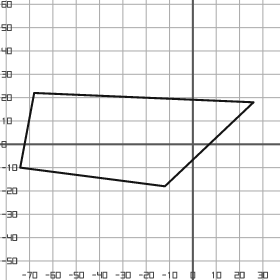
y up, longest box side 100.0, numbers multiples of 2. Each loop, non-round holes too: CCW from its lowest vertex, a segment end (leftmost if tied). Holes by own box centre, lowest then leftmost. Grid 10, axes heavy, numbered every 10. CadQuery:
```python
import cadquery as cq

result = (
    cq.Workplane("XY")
    .moveTo(-12.0, -18.0)
    .lineTo(26.0, 18.0)
    .lineTo(-68.0, 22.0)
    .lineTo(-74.0, -10.0)
    .close()
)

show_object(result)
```